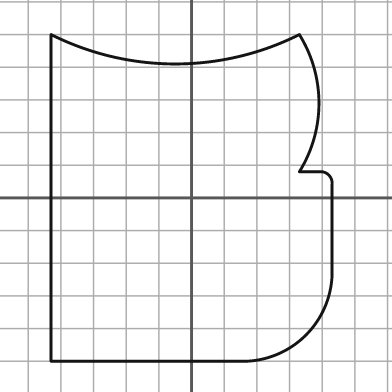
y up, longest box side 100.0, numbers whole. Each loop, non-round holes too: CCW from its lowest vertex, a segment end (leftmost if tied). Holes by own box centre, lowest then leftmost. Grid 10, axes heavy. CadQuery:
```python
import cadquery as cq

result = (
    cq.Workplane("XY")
    .moveTo(-43.0, -50.0)
    .lineTo(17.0, -50.0)
    .threePointArc((35.0, -42.0), (43.0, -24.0))
    .lineTo(43.0, 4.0)
    .threePointArc((42.0, 7.0), (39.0, 8.0))
    .lineTo(33.0, 8.0)
    .threePointArc((39.0, 29.0), (33.0, 50.0))
    .threePointArc((-5.0, 41.0), (-43.0, 50.0))
    .close()
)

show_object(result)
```